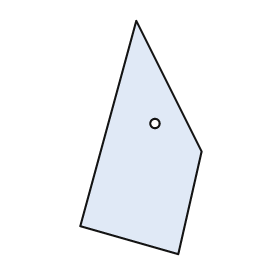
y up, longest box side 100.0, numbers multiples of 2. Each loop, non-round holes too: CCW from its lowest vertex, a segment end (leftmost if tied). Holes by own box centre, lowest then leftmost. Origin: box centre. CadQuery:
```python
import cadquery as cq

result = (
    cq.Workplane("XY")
    .moveTo(16.0, -50.0)
    .lineTo(26.0, -6.0)
    .lineTo(-2.0, 50.0)
    .lineTo(-26.0, -38.0)
    .close()
    .moveTo(6.0, 6.0)
    .circle(2.0)
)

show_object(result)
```